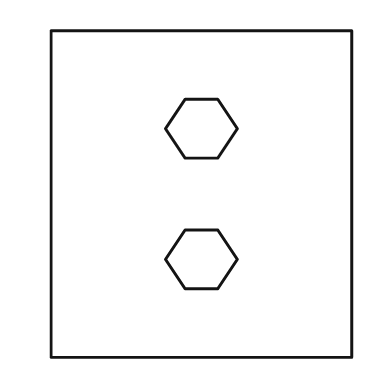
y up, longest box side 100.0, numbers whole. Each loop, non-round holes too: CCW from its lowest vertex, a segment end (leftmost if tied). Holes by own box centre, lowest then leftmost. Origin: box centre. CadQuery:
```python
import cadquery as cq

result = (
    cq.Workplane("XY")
    .moveTo(-46.0, -50.0)
    .lineTo(46.0, -50.0)
    .lineTo(46.0, 50.0)
    .lineTo(-46.0, 50.0)
    .close()
    .moveTo(-5.0, -29.0)
    .lineTo(5.0, -29.0)
    .lineTo(11.0, -20.0)
    .lineTo(5.0, -11.0)
    .lineTo(-5.0, -11.0)
    .lineTo(-11.0, -20.0)
    .close()
    .moveTo(-5.0, 11.0)
    .lineTo(5.0, 11.0)
    .lineTo(11.0, 20.0)
    .lineTo(5.0, 29.0)
    .lineTo(-5.0, 29.0)
    .lineTo(-11.0, 20.0)
    .close()
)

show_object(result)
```